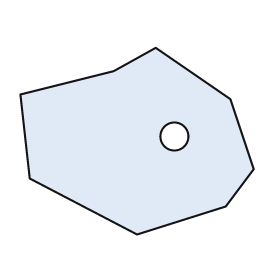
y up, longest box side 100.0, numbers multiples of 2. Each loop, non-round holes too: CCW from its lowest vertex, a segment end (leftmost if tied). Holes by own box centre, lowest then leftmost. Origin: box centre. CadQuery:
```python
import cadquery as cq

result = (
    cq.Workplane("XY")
    .moveTo(0.0, -40.0)
    .lineTo(38.0, -28.0)
    .lineTo(50.0, -12.0)
    .lineTo(40.0, 18.0)
    .lineTo(8.0, 40.0)
    .lineTo(-10.0, 30.0)
    .lineTo(-50.0, 20.0)
    .lineTo(-46.0, -16.0)
    .close()
    .moveTo(16.0, 2.0)
    .circle(6.0)
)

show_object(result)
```